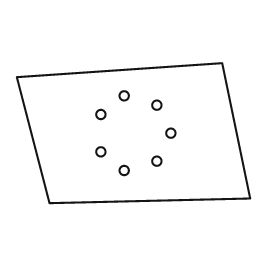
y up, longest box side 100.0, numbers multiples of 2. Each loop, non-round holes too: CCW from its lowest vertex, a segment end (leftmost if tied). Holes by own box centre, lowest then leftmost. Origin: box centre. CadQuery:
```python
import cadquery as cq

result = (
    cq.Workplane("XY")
    .moveTo(-36.0, -30.0)
    .lineTo(50.0, -28.0)
    .lineTo(38.0, 30.0)
    .lineTo(-50.0, 24.0)
    .close()
    .moveTo(-4.0, -16.0)
    .circle(2.0)
    .moveTo(10.0, -12.0)
    .circle(2.0)
    .moveTo(-14.0, -8.0)
    .circle(2.0)
    .moveTo(16.0, 0.0)
    .circle(2.0)
    .moveTo(-14.0, 8.0)
    .circle(2.0)
    .moveTo(10.0, 12.0)
    .circle(2.0)
    .moveTo(-4.0, 16.0)
    .circle(2.0)
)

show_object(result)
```